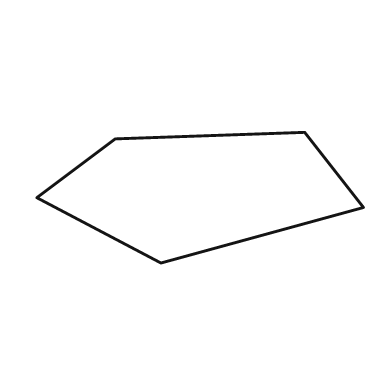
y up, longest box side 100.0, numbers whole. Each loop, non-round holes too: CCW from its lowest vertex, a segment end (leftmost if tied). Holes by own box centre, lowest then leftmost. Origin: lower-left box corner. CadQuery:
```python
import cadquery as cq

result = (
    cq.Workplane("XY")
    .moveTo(38.0, 0.0)
    .lineTo(100.0, 17.0)
    .lineTo(82.0, 40.0)
    .lineTo(24.0, 38.0)
    .lineTo(0.0, 20.0)
    .close()
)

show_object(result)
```